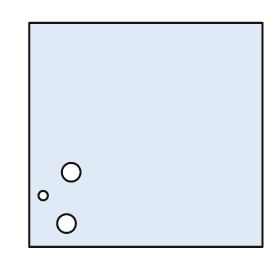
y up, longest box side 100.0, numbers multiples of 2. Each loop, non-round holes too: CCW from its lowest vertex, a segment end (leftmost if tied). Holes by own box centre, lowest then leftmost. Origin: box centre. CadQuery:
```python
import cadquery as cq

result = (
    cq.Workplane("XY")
    .moveTo(-50.0, -48.0)
    .lineTo(50.0, -48.0)
    .lineTo(50.0, 48.0)
    .lineTo(-50.0, 48.0)
    .close()
    .moveTo(-34.0, -38.0)
    .circle(4.0)
    .moveTo(-44.0, -26.0)
    .circle(2.0)
    .moveTo(-32.0, -16.0)
    .circle(4.0)
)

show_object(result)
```